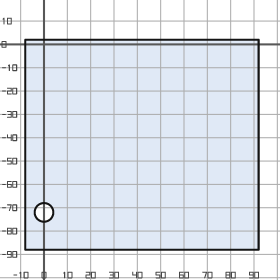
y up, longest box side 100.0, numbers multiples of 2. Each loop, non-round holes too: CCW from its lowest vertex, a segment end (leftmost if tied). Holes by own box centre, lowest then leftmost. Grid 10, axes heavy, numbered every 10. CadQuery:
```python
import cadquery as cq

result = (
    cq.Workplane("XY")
    .moveTo(-8.0, -88.0)
    .lineTo(92.0, -88.0)
    .lineTo(92.0, 2.0)
    .lineTo(-8.0, 2.0)
    .close()
    .moveTo(0.0, -72.0)
    .circle(4.0)
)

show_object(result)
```